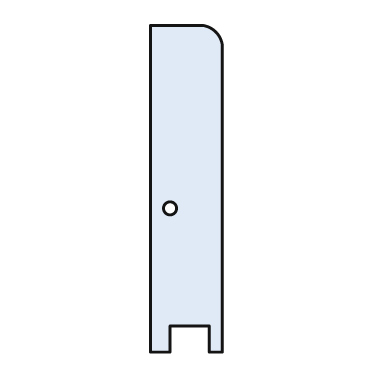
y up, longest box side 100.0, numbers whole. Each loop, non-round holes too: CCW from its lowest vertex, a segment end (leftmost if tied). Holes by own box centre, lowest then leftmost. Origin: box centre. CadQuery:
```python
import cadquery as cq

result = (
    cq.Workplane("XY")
    .moveTo(-11.0, -50.0)
    .lineTo(-5.0, -50.0)
    .lineTo(-5.0, -42.0)
    .lineTo(7.0, -42.0)
    .lineTo(7.0, -50.0)
    .lineTo(11.0, -50.0)
    .lineTo(11.0, 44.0)
    .threePointArc((9.0, 48.0), (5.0, 50.0))
    .lineTo(-11.0, 50.0)
    .close()
    .moveTo(-5.0, -6.0)
    .circle(2.0)
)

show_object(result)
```